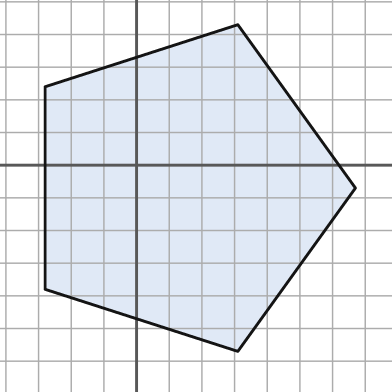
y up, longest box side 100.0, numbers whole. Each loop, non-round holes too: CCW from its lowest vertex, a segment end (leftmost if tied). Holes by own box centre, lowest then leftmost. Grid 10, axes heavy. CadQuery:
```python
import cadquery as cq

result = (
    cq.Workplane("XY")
    .moveTo(31.0, -57.0)
    .lineTo(67.0, -7.0)
    .lineTo(31.0, 43.0)
    .lineTo(-28.0, 24.0)
    .lineTo(-28.0, -38.0)
    .close()
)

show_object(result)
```